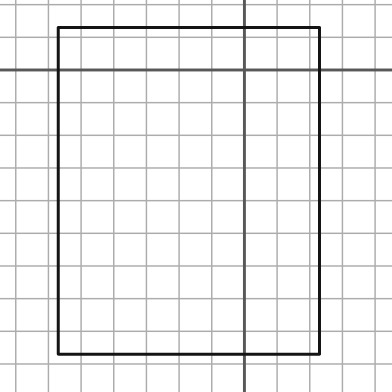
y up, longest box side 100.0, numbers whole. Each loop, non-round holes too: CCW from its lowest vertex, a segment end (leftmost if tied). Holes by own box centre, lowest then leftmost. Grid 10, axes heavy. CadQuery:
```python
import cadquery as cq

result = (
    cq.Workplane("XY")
    .moveTo(-57.0, -87.0)
    .lineTo(23.0, -87.0)
    .lineTo(23.0, 13.0)
    .lineTo(-57.0, 13.0)
    .close()
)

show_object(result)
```